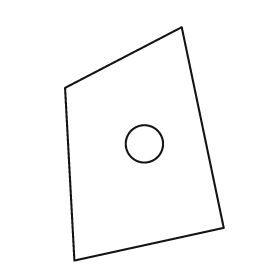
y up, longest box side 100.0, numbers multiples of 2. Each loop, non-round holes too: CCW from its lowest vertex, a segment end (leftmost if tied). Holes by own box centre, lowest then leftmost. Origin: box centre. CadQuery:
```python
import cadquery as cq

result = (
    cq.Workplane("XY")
    .moveTo(-30.0, -50.0)
    .lineTo(34.0, -36.0)
    .lineTo(16.0, 50.0)
    .lineTo(-34.0, 24.0)
    .close()
    .moveTo(0.0, 0.0)
    .circle(8.0)
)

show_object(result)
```